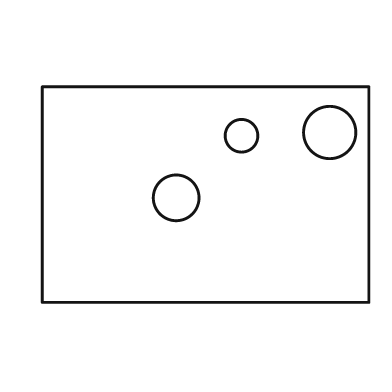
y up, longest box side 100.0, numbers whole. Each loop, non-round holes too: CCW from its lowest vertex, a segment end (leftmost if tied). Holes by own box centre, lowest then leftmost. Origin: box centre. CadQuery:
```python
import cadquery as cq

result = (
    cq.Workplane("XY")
    .moveTo(-50.0, -33.0)
    .lineTo(50.0, -33.0)
    .lineTo(50.0, 33.0)
    .lineTo(-50.0, 33.0)
    .close()
    .moveTo(-9.0, -1.0)
    .circle(7.0)
    .moveTo(11.0, 18.0)
    .circle(5.0)
    .moveTo(38.0, 19.0)
    .circle(8.0)
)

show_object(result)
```